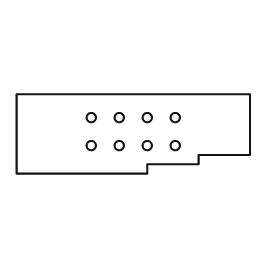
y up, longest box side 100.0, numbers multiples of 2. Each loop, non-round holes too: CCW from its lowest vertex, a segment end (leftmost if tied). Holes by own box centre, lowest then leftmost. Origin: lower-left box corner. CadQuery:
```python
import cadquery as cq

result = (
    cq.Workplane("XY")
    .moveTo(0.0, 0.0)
    .lineTo(56.0, 0.0)
    .lineTo(56.0, 4.0)
    .lineTo(78.0, 4.0)
    .lineTo(78.0, 8.0)
    .lineTo(100.0, 8.0)
    .lineTo(100.0, 34.0)
    .lineTo(0.0, 34.0)
    .close()
    .moveTo(32.0, 12.0)
    .circle(2.0)
    .moveTo(44.0, 12.0)
    .circle(2.0)
    .moveTo(56.0, 12.0)
    .circle(2.0)
    .moveTo(68.0, 12.0)
    .circle(2.0)
    .moveTo(32.0, 24.0)
    .circle(2.0)
    .moveTo(44.0, 24.0)
    .circle(2.0)
    .moveTo(56.0, 24.0)
    .circle(2.0)
    .moveTo(68.0, 24.0)
    .circle(2.0)
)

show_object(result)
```